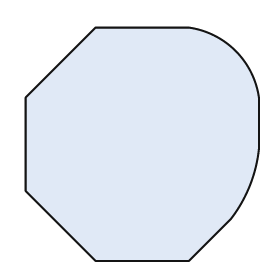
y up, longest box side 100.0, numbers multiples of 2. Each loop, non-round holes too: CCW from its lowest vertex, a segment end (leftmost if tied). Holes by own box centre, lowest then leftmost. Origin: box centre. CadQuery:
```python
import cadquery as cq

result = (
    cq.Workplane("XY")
    .moveTo(-20.0, -50.0)
    .lineTo(20.0, -50.0)
    .lineTo(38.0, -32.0)
    .threePointArc((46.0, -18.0), (50.0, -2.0))
    .lineTo(50.0, 20.0)
    .threePointArc((40.0, 40.0), (20.0, 50.0))
    .lineTo(-20.0, 50.0)
    .lineTo(-50.0, 20.0)
    .lineTo(-50.0, -20.0)
    .close()
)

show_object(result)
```